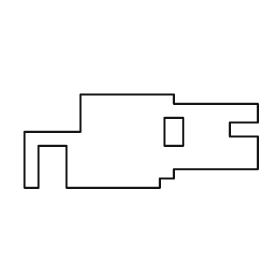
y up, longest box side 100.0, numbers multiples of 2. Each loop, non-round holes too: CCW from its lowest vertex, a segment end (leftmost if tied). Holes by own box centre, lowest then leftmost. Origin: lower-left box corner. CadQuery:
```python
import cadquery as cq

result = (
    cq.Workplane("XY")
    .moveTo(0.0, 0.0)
    .lineTo(6.0, 0.0)
    .lineTo(6.0, 18.0)
    .lineTo(18.0, 18.0)
    .lineTo(18.0, 0.0)
    .lineTo(58.0, 0.0)
    .lineTo(58.0, 4.0)
    .lineTo(64.0, 4.0)
    .lineTo(64.0, 8.0)
    .lineTo(100.0, 8.0)
    .lineTo(100.0, 22.0)
    .lineTo(88.0, 22.0)
    .lineTo(88.0, 28.0)
    .lineTo(100.0, 28.0)
    .lineTo(100.0, 36.0)
    .lineTo(64.0, 36.0)
    .lineTo(64.0, 40.0)
    .lineTo(24.0, 40.0)
    .lineTo(24.0, 24.0)
    .lineTo(0.0, 24.0)
    .close()
    .moveTo(60.0, 18.0)
    .lineTo(68.0, 18.0)
    .lineTo(68.0, 30.0)
    .lineTo(60.0, 30.0)
    .close()
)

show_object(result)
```